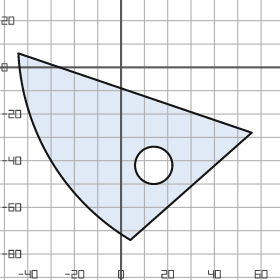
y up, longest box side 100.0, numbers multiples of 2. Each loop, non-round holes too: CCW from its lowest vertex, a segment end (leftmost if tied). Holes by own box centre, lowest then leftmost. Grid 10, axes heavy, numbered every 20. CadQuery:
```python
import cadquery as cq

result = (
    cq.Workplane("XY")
    .moveTo(4.0, -74.0)
    .lineTo(56.0, -28.0)
    .lineTo(-44.0, 6.0)
    .threePointArc((-30.0, -40.0), (4.0, -74.0))
    .close()
    .moveTo(14.0, -42.0)
    .circle(8.0)
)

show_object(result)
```